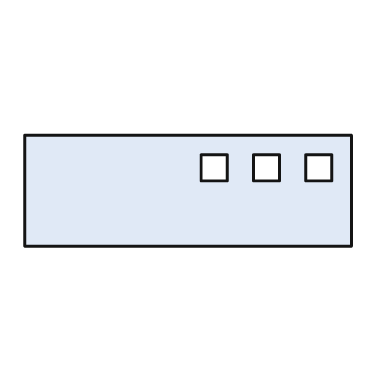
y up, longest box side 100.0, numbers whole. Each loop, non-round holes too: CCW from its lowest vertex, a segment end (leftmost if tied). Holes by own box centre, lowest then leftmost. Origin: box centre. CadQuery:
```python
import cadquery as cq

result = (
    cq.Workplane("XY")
    .moveTo(-50.0, -17.0)
    .lineTo(50.0, -17.0)
    .lineTo(50.0, 17.0)
    .lineTo(-50.0, 17.0)
    .close()
    .moveTo(4.0, 3.0)
    .lineTo(12.0, 3.0)
    .lineTo(12.0, 11.0)
    .lineTo(4.0, 11.0)
    .close()
    .moveTo(20.0, 3.0)
    .lineTo(28.0, 3.0)
    .lineTo(28.0, 11.0)
    .lineTo(20.0, 11.0)
    .close()
    .moveTo(36.0, 3.0)
    .lineTo(44.0, 3.0)
    .lineTo(44.0, 11.0)
    .lineTo(36.0, 11.0)
    .close()
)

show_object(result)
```